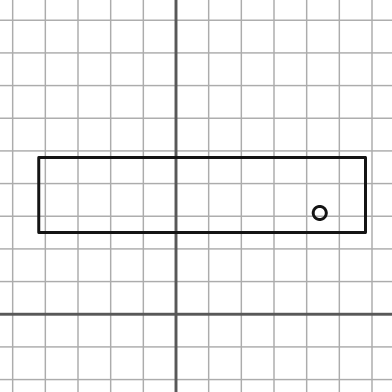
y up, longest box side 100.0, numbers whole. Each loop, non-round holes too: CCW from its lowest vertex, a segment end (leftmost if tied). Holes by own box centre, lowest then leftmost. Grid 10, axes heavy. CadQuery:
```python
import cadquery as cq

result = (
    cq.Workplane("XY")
    .moveTo(-42.0, 25.0)
    .lineTo(58.0, 25.0)
    .lineTo(58.0, 48.0)
    .lineTo(-42.0, 48.0)
    .close()
    .moveTo(44.0, 31.0)
    .circle(2.0)
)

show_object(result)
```